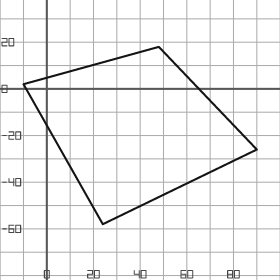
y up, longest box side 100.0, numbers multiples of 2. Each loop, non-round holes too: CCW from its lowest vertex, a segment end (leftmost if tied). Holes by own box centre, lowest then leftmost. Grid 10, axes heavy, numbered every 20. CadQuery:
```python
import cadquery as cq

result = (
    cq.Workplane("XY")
    .moveTo(24.0, -58.0)
    .lineTo(90.0, -26.0)
    .lineTo(48.0, 18.0)
    .lineTo(-10.0, 2.0)
    .close()
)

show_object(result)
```